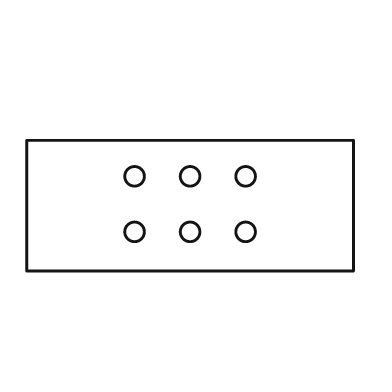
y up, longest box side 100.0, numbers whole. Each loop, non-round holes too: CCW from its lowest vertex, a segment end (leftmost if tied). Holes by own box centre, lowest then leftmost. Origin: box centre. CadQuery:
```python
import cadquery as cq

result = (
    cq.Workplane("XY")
    .moveTo(-50.0, -20.0)
    .lineTo(50.0, -20.0)
    .lineTo(50.0, 20.0)
    .lineTo(-50.0, 20.0)
    .close()
    .moveTo(-17.0, -8.0)
    .circle(3.0)
    .moveTo(0.0, -8.0)
    .circle(3.0)
    .moveTo(17.0, -8.0)
    .circle(3.0)
    .moveTo(-17.0, 9.0)
    .circle(3.0)
    .moveTo(0.0, 9.0)
    .circle(3.0)
    .moveTo(17.0, 9.0)
    .circle(3.0)
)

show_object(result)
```